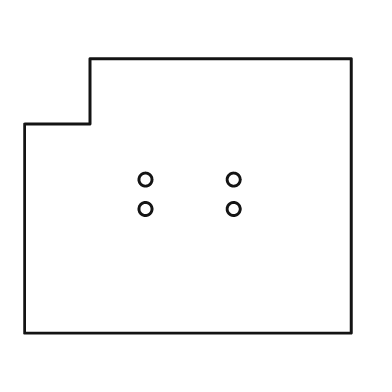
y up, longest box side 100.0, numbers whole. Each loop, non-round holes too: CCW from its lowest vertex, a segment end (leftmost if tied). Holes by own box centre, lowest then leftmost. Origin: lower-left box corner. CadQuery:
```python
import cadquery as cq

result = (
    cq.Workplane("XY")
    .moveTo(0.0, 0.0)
    .lineTo(100.0, 0.0)
    .lineTo(100.0, 84.0)
    .lineTo(20.0, 84.0)
    .lineTo(20.0, 64.0)
    .lineTo(0.0, 64.0)
    .close()
    .moveTo(37.0, 38.0)
    .circle(2.0)
    .moveTo(64.0, 38.0)
    .circle(2.0)
    .moveTo(37.0, 47.0)
    .circle(2.0)
    .moveTo(64.0, 47.0)
    .circle(2.0)
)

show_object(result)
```